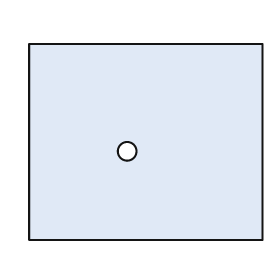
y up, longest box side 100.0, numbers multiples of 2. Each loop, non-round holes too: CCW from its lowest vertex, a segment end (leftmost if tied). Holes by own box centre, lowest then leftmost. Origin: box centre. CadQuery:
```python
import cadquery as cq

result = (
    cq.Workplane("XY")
    .moveTo(-50.0, -42.0)
    .lineTo(50.0, -42.0)
    .lineTo(50.0, 42.0)
    .lineTo(-50.0, 42.0)
    .close()
    .moveTo(-8.0, -4.0)
    .circle(4.0)
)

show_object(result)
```